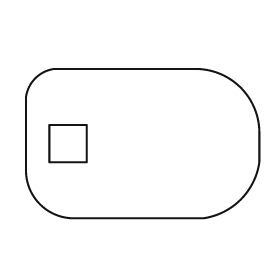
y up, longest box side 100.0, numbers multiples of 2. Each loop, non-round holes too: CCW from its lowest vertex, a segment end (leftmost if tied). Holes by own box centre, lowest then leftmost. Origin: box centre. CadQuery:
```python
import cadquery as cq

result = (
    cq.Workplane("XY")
    .moveTo(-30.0, -32.0)
    .lineTo(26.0, -32.0)
    .threePointArc((42.0, -24.0), (50.0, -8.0))
    .lineTo(50.0, 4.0)
    .threePointArc((42.0, 24.0), (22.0, 32.0))
    .lineTo(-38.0, 32.0)
    .threePointArc((-46.0, 28.0), (-50.0, 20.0))
    .lineTo(-50.0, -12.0)
    .threePointArc((-44.0, -26.0), (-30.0, -32.0))
    .close()
    .moveTo(-40.0, -8.0)
    .lineTo(-24.0, -8.0)
    .lineTo(-24.0, 8.0)
    .lineTo(-40.0, 8.0)
    .close()
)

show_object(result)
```